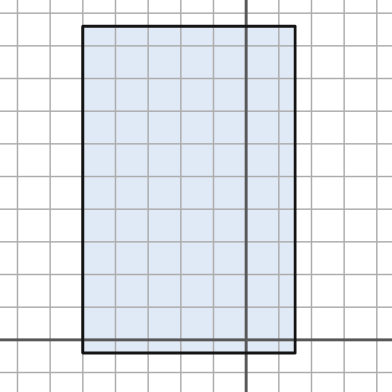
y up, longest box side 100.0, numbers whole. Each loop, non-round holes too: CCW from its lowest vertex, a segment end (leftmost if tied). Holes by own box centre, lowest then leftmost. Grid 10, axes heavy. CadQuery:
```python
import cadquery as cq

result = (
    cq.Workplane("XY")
    .moveTo(-50.0, -4.0)
    .lineTo(15.0, -4.0)
    .lineTo(15.0, 96.0)
    .lineTo(-50.0, 96.0)
    .close()
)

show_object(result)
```